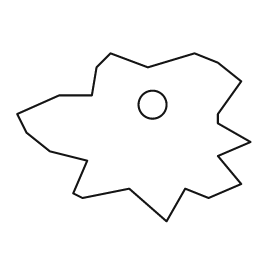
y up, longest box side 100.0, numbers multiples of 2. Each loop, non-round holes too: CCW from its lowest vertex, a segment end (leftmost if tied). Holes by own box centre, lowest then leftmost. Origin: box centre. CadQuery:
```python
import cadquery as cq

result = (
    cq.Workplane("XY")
    .moveTo(14.0, -36.0)
    .lineTo(22.0, -22.0)
    .lineTo(32.0, -26.0)
    .lineTo(46.0, -20.0)
    .lineTo(36.0, -8.0)
    .lineTo(50.0, -2.0)
    .lineTo(36.0, 6.0)
    .lineTo(36.0, 10.0)
    .lineTo(46.0, 24.0)
    .lineTo(36.0, 32.0)
    .lineTo(26.0, 36.0)
    .lineTo(6.0, 30.0)
    .lineTo(-10.0, 36.0)
    .lineTo(-16.0, 30.0)
    .lineTo(-18.0, 18.0)
    .lineTo(-32.0, 18.0)
    .lineTo(-50.0, 10.0)
    .lineTo(-46.0, 2.0)
    .lineTo(-36.0, -6.0)
    .lineTo(-20.0, -10.0)
    .lineTo(-26.0, -24.0)
    .lineTo(-22.0, -26.0)
    .lineTo(-2.0, -22.0)
    .close()
    .moveTo(8.0, 14.0)
    .circle(6.0)
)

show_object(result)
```